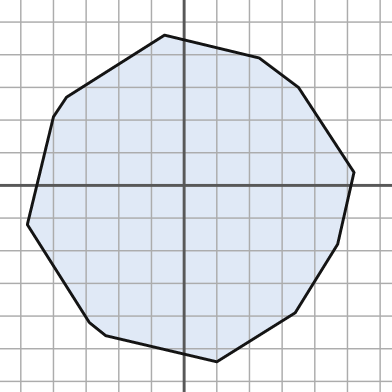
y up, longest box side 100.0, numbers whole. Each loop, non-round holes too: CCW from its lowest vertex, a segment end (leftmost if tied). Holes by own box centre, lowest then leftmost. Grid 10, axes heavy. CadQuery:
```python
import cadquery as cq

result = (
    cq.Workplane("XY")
    .moveTo(10.0, -54.0)
    .lineTo(34.0, -39.0)
    .lineTo(47.0, -18.0)
    .lineTo(52.0, 4.0)
    .lineTo(35.0, 30.0)
    .lineTo(23.0, 39.0)
    .lineTo(-6.0, 46.0)
    .lineTo(-36.0, 27.0)
    .lineTo(-40.0, 21.0)
    .lineTo(-48.0, -12.0)
    .lineTo(-29.0, -42.0)
    .lineTo(-24.0, -46.0)
    .close()
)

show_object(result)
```